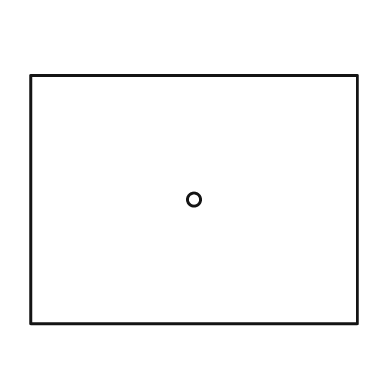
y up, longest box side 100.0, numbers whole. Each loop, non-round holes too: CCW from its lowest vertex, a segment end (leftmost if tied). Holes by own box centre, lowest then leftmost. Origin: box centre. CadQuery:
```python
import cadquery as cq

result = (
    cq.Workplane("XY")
    .moveTo(-50.0, -38.0)
    .lineTo(50.0, -38.0)
    .lineTo(50.0, 38.0)
    .lineTo(-50.0, 38.0)
    .close()
    .moveTo(0.0, 0.0)
    .circle(2.0)
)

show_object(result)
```